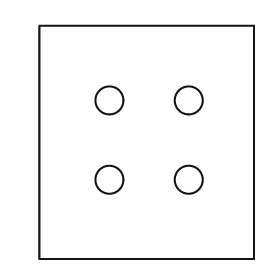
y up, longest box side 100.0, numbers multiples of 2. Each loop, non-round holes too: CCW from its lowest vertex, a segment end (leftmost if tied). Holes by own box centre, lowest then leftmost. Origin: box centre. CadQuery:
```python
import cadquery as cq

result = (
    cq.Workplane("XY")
    .moveTo(-46.0, -50.0)
    .lineTo(46.0, -50.0)
    .lineTo(46.0, 50.0)
    .lineTo(-46.0, 50.0)
    .close()
    .moveTo(-16.0, -16.0)
    .circle(6.0)
    .moveTo(18.0, -16.0)
    .circle(6.0)
    .moveTo(-16.0, 18.0)
    .circle(6.0)
    .moveTo(18.0, 18.0)
    .circle(6.0)
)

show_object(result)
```